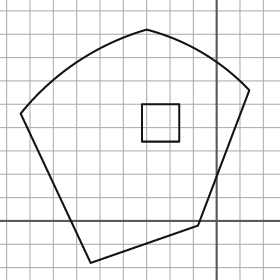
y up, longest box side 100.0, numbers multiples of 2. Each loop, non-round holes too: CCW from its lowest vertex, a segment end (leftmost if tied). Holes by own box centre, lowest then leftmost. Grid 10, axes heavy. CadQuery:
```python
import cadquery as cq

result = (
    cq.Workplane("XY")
    .moveTo(-54.0, -18.0)
    .lineTo(-8.0, -2.0)
    .lineTo(14.0, 56.0)
    .threePointArc((-6.0, 72.0), (-30.0, 82.0))
    .threePointArc((-60.0, 68.0), (-84.0, 46.0))
    .close()
    .moveTo(-32.0, 34.0)
    .lineTo(-16.0, 34.0)
    .lineTo(-16.0, 50.0)
    .lineTo(-32.0, 50.0)
    .close()
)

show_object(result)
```